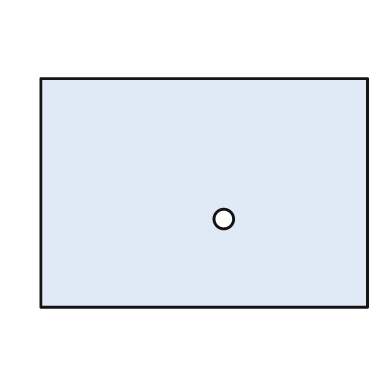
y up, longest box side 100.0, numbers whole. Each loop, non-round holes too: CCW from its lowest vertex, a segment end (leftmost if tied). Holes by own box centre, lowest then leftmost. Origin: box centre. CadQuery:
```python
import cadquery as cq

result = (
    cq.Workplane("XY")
    .moveTo(-50.0, -35.0)
    .lineTo(50.0, -35.0)
    .lineTo(50.0, 35.0)
    .lineTo(-50.0, 35.0)
    .close()
    .moveTo(6.0, -8.0)
    .circle(3.0)
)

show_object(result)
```